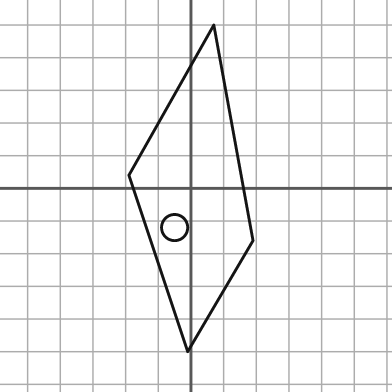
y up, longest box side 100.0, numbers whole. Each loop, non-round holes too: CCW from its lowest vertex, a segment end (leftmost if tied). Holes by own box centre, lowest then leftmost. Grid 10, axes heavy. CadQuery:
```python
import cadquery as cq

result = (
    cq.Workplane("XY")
    .moveTo(-1.0, -50.0)
    .lineTo(19.0, -16.0)
    .lineTo(7.0, 50.0)
    .lineTo(-19.0, 4.0)
    .close()
    .moveTo(-5.0, -12.0)
    .circle(4.0)
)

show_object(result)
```